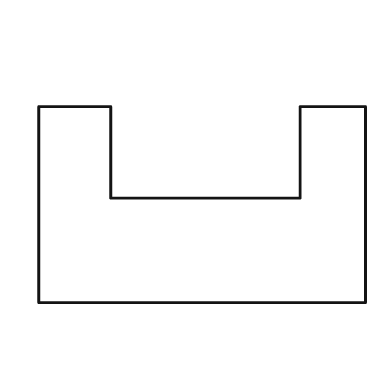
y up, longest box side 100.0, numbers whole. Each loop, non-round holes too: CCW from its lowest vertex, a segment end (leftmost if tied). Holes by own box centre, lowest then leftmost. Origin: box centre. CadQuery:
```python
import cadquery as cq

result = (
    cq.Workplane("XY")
    .moveTo(-50.0, -30.0)
    .lineTo(50.0, -30.0)
    .lineTo(50.0, 30.0)
    .lineTo(30.0, 30.0)
    .lineTo(30.0, 2.0)
    .lineTo(-28.0, 2.0)
    .lineTo(-28.0, 30.0)
    .lineTo(-50.0, 30.0)
    .close()
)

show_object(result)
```